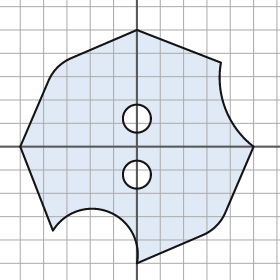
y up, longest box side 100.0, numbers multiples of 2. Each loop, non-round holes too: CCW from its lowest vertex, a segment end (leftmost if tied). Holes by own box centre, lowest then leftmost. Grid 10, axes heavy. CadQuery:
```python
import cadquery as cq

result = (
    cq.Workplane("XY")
    .moveTo(0.0, -50.0)
    .lineTo(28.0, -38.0)
    .threePointArc((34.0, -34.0), (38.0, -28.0))
    .lineTo(50.0, 0.0)
    .threePointArc((38.0, 16.0), (36.0, 36.0))
    .lineTo(0.0, 50.0)
    .lineTo(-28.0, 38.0)
    .threePointArc((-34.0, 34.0), (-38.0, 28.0))
    .lineTo(-50.0, 0.0)
    .lineTo(-36.0, -36.0)
    .threePointArc((-12.0, -28.0), (0.0, -50.0))
    .close()
    .moveTo(0.0, -12.0)
    .circle(6.0)
    .moveTo(0.0, 12.0)
    .circle(6.0)
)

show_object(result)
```